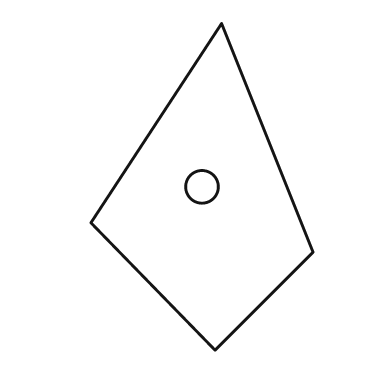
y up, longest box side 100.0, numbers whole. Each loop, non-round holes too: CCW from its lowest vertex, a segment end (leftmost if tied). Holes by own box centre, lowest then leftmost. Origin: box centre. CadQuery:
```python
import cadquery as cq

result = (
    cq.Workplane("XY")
    .moveTo(4.0, -50.0)
    .lineTo(34.0, -20.0)
    .lineTo(6.0, 50.0)
    .lineTo(-34.0, -11.0)
    .close()
    .moveTo(0.0, 0.0)
    .circle(5.0)
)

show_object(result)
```